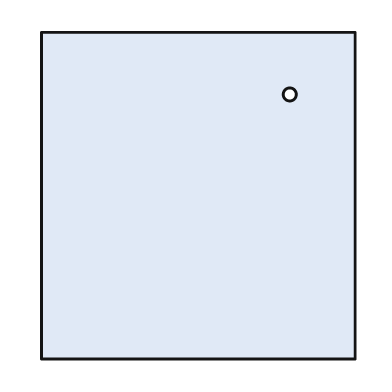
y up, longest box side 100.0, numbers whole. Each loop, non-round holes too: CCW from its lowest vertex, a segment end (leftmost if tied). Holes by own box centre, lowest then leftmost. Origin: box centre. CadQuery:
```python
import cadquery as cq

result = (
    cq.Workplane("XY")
    .moveTo(-48.0, -50.0)
    .lineTo(48.0, -50.0)
    .lineTo(48.0, 50.0)
    .lineTo(-48.0, 50.0)
    .close()
    .moveTo(28.0, 31.0)
    .circle(2.0)
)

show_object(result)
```